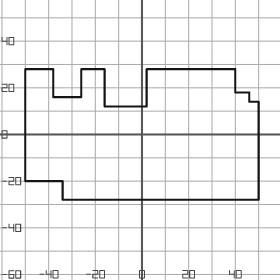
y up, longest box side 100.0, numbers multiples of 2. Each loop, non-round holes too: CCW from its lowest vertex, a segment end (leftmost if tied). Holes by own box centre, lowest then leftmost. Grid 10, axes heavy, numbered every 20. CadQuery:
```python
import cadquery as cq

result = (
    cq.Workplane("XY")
    .moveTo(-34.0, -28.0)
    .lineTo(50.0, -28.0)
    .lineTo(50.0, 14.0)
    .lineTo(46.0, 14.0)
    .lineTo(46.0, 18.0)
    .lineTo(40.0, 18.0)
    .lineTo(40.0, 28.0)
    .lineTo(2.0, 28.0)
    .lineTo(2.0, 12.0)
    .lineTo(-16.0, 12.0)
    .lineTo(-16.0, 28.0)
    .lineTo(-26.0, 28.0)
    .lineTo(-26.0, 16.0)
    .lineTo(-38.0, 16.0)
    .lineTo(-38.0, 28.0)
    .lineTo(-50.0, 28.0)
    .lineTo(-50.0, -20.0)
    .lineTo(-34.0, -20.0)
    .close()
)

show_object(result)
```